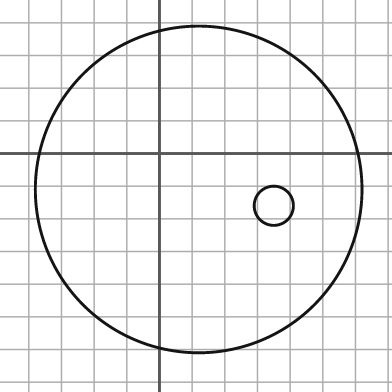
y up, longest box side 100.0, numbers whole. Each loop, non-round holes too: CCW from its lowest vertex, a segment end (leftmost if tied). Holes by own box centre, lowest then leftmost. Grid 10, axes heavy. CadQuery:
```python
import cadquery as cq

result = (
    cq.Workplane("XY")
    .moveTo(12.0, -11.0)
    .circle(50.0)
    .moveTo(35.0, -16.0)
    .circle(6.0)
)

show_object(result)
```